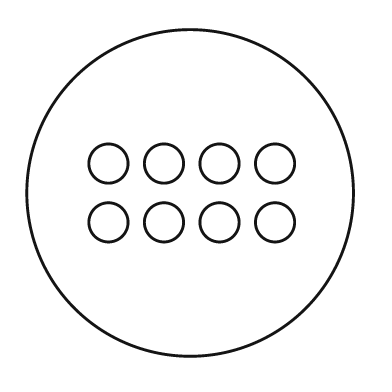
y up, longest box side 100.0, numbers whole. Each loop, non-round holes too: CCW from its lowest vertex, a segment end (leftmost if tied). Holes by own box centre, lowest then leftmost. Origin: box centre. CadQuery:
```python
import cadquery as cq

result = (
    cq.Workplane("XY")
    .moveTo(0.0, 0.0)
    .circle(50.0)
    .moveTo(-25.0, -9.0)
    .circle(6.0)
    .moveTo(-8.0, -9.0)
    .circle(6.0)
    .moveTo(9.0, -9.0)
    .circle(6.0)
    .moveTo(26.0, -9.0)
    .circle(6.0)
    .moveTo(-25.0, 9.0)
    .circle(6.0)
    .moveTo(-8.0, 9.0)
    .circle(6.0)
    .moveTo(9.0, 9.0)
    .circle(6.0)
    .moveTo(26.0, 9.0)
    .circle(6.0)
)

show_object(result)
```